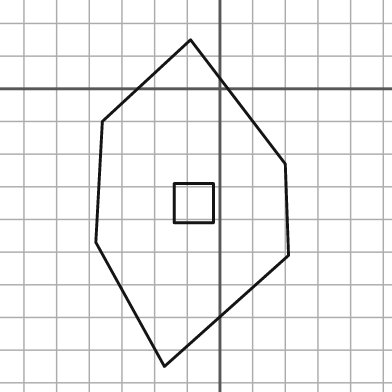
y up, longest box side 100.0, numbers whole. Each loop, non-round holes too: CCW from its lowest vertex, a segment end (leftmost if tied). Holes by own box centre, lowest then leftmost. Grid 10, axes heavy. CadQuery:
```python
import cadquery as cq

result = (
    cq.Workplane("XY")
    .moveTo(-17.0, -85.0)
    .lineTo(21.0, -51.0)
    .lineTo(20.0, -23.0)
    .lineTo(-9.0, 15.0)
    .lineTo(-36.0, -10.0)
    .lineTo(-38.0, -47.0)
    .close()
    .moveTo(-14.0, -41.0)
    .lineTo(-2.0, -41.0)
    .lineTo(-2.0, -29.0)
    .lineTo(-14.0, -29.0)
    .close()
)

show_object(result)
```